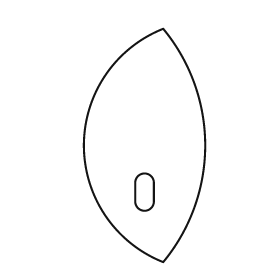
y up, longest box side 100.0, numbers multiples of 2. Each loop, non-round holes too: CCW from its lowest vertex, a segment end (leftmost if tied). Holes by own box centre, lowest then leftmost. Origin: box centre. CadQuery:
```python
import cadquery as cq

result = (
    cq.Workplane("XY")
    .moveTo(8.0, -50.0)
    .threePointArc((26.0, 0.0), (8.0, 50.0))
    .threePointArc((-26.0, 0.0), (8.0, -50.0))
    .close()
    .moveTo(-4.0, -24.0)
    .threePointArc((0.0, -28.0), (4.0, -24.0))
    .lineTo(4.0, -16.0)
    .threePointArc((0.0, -12.0), (-4.0, -16.0))
    .close()
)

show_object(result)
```